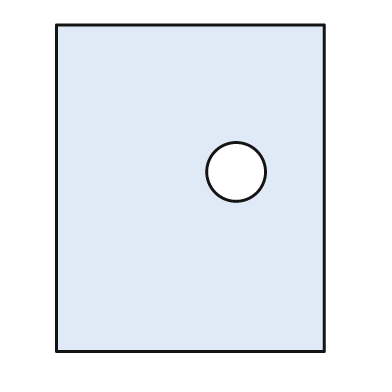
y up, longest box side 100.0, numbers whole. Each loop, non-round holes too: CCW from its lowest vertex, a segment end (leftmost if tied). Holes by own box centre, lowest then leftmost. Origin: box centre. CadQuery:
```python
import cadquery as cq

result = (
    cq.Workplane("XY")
    .moveTo(-41.0, -50.0)
    .lineTo(41.0, -50.0)
    .lineTo(41.0, 50.0)
    .lineTo(-41.0, 50.0)
    .close()
    .moveTo(14.0, 5.0)
    .circle(9.0)
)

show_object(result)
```